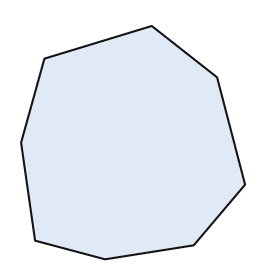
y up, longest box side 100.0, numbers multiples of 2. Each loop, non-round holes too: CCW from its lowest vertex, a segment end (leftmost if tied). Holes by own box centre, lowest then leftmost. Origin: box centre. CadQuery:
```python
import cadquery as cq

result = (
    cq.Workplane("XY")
    .moveTo(-12.0, -50.0)
    .lineTo(26.0, -44.0)
    .lineTo(48.0, -18.0)
    .lineTo(36.0, 28.0)
    .lineTo(8.0, 50.0)
    .lineTo(-38.0, 36.0)
    .lineTo(-48.0, 0.0)
    .lineTo(-42.0, -42.0)
    .close()
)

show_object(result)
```